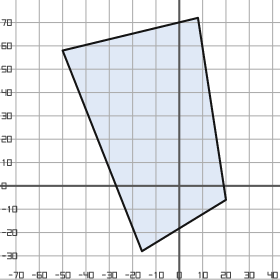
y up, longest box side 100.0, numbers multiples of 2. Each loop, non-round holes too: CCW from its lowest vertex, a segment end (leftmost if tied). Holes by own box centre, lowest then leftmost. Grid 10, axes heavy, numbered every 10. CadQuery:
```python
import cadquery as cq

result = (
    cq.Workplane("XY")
    .moveTo(-16.0, -28.0)
    .lineTo(20.0, -6.0)
    .lineTo(8.0, 72.0)
    .lineTo(-50.0, 58.0)
    .close()
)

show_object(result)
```